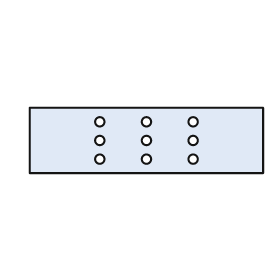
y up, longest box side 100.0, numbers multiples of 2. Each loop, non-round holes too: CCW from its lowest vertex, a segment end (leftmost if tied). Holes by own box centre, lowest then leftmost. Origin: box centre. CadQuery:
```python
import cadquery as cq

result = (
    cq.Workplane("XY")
    .moveTo(-50.0, -14.0)
    .lineTo(50.0, -14.0)
    .lineTo(50.0, 14.0)
    .lineTo(-50.0, 14.0)
    .close()
    .moveTo(-20.0, -8.0)
    .circle(2.0)
    .moveTo(0.0, -8.0)
    .circle(2.0)
    .moveTo(20.0, -8.0)
    .circle(2.0)
    .moveTo(-20.0, 0.0)
    .circle(2.0)
    .moveTo(0.0, 0.0)
    .circle(2.0)
    .moveTo(20.0, 0.0)
    .circle(2.0)
    .moveTo(-20.0, 8.0)
    .circle(2.0)
    .moveTo(0.0, 8.0)
    .circle(2.0)
    .moveTo(20.0, 8.0)
    .circle(2.0)
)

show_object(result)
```